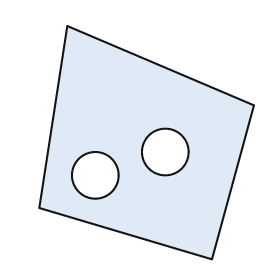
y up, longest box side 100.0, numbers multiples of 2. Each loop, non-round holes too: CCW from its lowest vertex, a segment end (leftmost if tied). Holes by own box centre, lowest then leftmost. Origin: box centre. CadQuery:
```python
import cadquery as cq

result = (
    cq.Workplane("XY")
    .moveTo(28.0, -50.0)
    .lineTo(46.0, 16.0)
    .lineTo(-34.0, 50.0)
    .lineTo(-46.0, -28.0)
    .close()
    .moveTo(-22.0, -14.0)
    .circle(10.0)
    .moveTo(8.0, -4.0)
    .circle(10.0)
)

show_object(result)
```